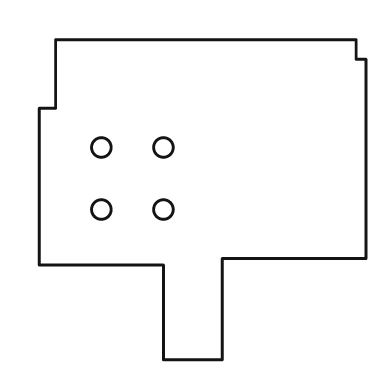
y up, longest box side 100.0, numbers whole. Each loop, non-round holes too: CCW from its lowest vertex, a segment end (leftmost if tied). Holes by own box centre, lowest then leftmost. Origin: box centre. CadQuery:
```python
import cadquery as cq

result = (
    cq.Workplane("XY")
    .moveTo(-12.0, -49.0)
    .lineTo(6.0, -49.0)
    .lineTo(6.0, -18.0)
    .lineTo(50.0, -18.0)
    .lineTo(50.0, 43.0)
    .lineTo(47.0, 43.0)
    .lineTo(47.0, 49.0)
    .lineTo(-45.0, 49.0)
    .lineTo(-45.0, 28.0)
    .lineTo(-50.0, 28.0)
    .lineTo(-50.0, -20.0)
    .lineTo(-12.0, -20.0)
    .close()
    .moveTo(-31.0, -3.0)
    .circle(3.0)
    .moveTo(-12.0, -3.0)
    .circle(3.0)
    .moveTo(-31.0, 16.0)
    .circle(3.0)
    .moveTo(-12.0, 16.0)
    .circle(3.0)
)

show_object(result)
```